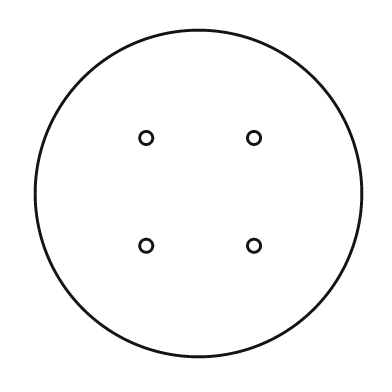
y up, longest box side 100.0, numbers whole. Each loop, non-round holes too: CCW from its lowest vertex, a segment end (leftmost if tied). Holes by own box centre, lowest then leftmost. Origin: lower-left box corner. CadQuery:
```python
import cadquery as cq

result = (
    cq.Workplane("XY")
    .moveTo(50.0, 50.0)
    .circle(50.0)
    .moveTo(34.0, 34.0)
    .circle(2.0)
    .moveTo(67.0, 34.0)
    .circle(2.0)
    .moveTo(34.0, 67.0)
    .circle(2.0)
    .moveTo(67.0, 67.0)
    .circle(2.0)
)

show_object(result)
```